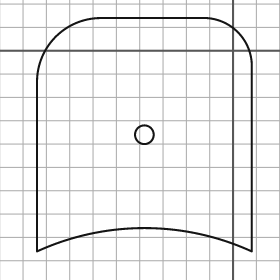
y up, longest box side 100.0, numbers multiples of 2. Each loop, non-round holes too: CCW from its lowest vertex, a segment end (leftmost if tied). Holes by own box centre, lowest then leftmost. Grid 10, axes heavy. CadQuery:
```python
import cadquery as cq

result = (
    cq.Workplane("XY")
    .moveTo(-84.0, -86.0)
    .threePointArc((-38.0, -76.0), (8.0, -86.0))
    .lineTo(8.0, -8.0)
    .threePointArc((2.0, 8.0), (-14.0, 14.0))
    .lineTo(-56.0, 14.0)
    .threePointArc((-76.0, 6.0), (-84.0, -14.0))
    .close()
    .moveTo(-38.0, -36.0)
    .circle(4.0)
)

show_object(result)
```